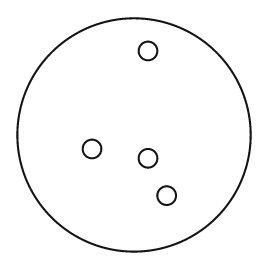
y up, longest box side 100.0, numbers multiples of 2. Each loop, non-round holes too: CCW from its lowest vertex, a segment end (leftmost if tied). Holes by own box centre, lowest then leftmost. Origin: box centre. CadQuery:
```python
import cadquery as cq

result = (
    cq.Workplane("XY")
    .moveTo(0.0, 0.0)
    .circle(50.0)
    .moveTo(14.0, -26.0)
    .circle(4.0)
    .moveTo(6.0, -10.0)
    .circle(4.0)
    .moveTo(-18.0, -6.0)
    .circle(4.0)
    .moveTo(6.0, 36.0)
    .circle(4.0)
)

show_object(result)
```